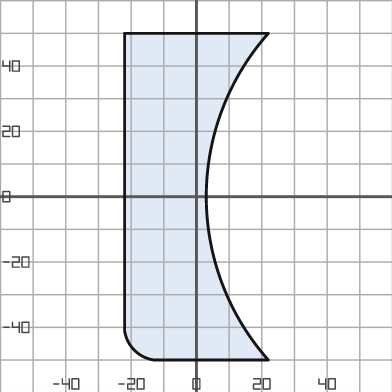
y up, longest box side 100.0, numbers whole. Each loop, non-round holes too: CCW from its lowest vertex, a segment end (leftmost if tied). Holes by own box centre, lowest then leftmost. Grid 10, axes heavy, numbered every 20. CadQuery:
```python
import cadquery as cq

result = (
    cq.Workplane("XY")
    .moveTo(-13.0, -50.0)
    .lineTo(22.0, -50.0)
    .threePointArc((3.0, 0.0), (22.0, 50.0))
    .lineTo(-22.0, 50.0)
    .lineTo(-22.0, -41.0)
    .threePointArc((-19.0, -47.0), (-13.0, -50.0))
    .close()
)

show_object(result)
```